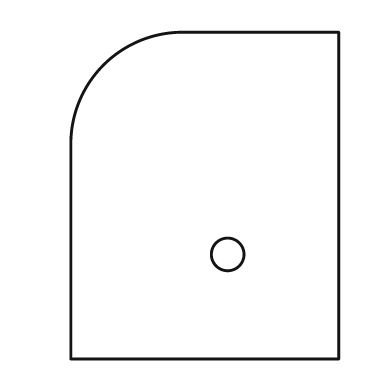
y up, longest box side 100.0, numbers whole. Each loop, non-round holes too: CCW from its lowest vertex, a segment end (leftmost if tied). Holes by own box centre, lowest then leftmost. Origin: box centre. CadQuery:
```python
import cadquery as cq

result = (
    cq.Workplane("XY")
    .moveTo(-41.0, -50.0)
    .lineTo(41.0, -50.0)
    .lineTo(41.0, 50.0)
    .lineTo(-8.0, 50.0)
    .threePointArc((-31.0, 40.0), (-41.0, 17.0))
    .close()
    .moveTo(7.0, -18.0)
    .circle(5.0)
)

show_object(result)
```